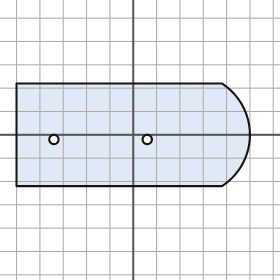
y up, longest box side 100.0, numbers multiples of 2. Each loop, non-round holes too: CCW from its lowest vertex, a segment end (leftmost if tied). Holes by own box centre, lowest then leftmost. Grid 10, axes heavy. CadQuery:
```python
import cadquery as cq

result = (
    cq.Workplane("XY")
    .moveTo(-50.0, -22.0)
    .lineTo(38.0, -22.0)
    .threePointArc((50.0, 0.0), (38.0, 22.0))
    .lineTo(-50.0, 22.0)
    .close()
    .moveTo(-34.0, -2.0)
    .circle(2.0)
    .moveTo(6.0, -2.0)
    .circle(2.0)
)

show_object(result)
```